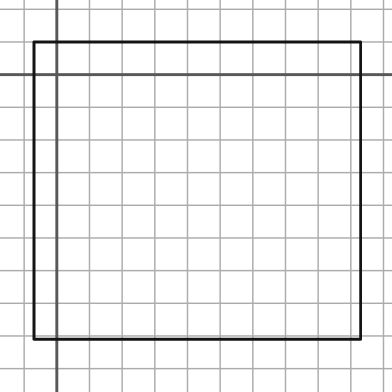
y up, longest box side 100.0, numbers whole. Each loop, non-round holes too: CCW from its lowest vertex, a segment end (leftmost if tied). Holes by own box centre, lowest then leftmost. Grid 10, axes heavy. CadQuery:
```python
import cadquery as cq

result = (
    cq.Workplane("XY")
    .moveTo(-7.0, -81.0)
    .lineTo(93.0, -81.0)
    .lineTo(93.0, 10.0)
    .lineTo(-7.0, 10.0)
    .close()
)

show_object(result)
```